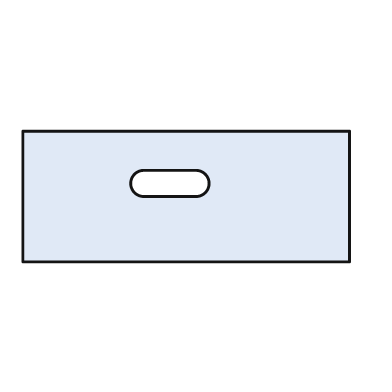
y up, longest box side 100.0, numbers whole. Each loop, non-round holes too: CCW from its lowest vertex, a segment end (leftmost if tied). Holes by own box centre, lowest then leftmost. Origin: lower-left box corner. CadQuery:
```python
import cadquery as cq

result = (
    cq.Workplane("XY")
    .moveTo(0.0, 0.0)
    .lineTo(100.0, 0.0)
    .lineTo(100.0, 40.0)
    .lineTo(0.0, 40.0)
    .close()
    .moveTo(37.0, 20.0)
    .lineTo(53.0, 20.0)
    .threePointArc((57.0, 24.0), (53.0, 28.0))
    .lineTo(37.0, 28.0)
    .threePointArc((33.0, 24.0), (37.0, 20.0))
    .close()
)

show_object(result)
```